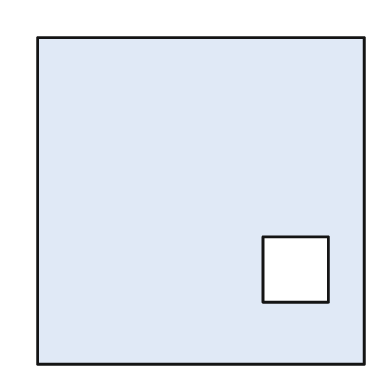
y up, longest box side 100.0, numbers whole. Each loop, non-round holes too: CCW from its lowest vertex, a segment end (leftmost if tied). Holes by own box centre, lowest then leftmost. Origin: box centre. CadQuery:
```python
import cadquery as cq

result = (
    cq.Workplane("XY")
    .moveTo(-50.0, -50.0)
    .lineTo(50.0, -50.0)
    .lineTo(50.0, 50.0)
    .lineTo(-50.0, 50.0)
    .close()
    .moveTo(19.0, -31.0)
    .lineTo(39.0, -31.0)
    .lineTo(39.0, -11.0)
    .lineTo(19.0, -11.0)
    .close()
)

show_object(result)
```